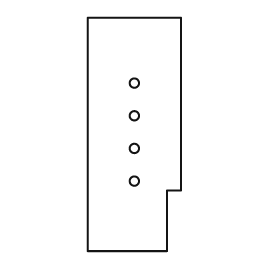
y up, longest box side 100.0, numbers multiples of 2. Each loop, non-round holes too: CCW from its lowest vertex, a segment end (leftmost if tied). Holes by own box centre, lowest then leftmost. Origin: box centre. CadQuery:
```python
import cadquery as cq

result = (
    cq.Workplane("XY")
    .moveTo(-20.0, -50.0)
    .lineTo(14.0, -50.0)
    .lineTo(14.0, -24.0)
    .lineTo(20.0, -24.0)
    .lineTo(20.0, 50.0)
    .lineTo(-20.0, 50.0)
    .close()
    .moveTo(0.0, -20.0)
    .circle(2.0)
    .moveTo(0.0, -6.0)
    .circle(2.0)
    .moveTo(0.0, 8.0)
    .circle(2.0)
    .moveTo(0.0, 22.0)
    .circle(2.0)
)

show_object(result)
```